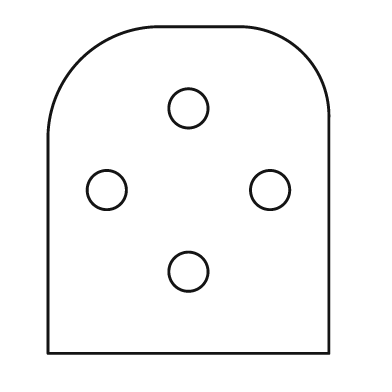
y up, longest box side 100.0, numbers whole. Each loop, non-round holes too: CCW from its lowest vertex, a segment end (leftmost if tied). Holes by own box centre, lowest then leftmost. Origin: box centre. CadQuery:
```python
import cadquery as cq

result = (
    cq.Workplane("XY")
    .moveTo(-43.0, -50.0)
    .lineTo(43.0, -50.0)
    .lineTo(43.0, 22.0)
    .threePointArc((35.0, 42.0), (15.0, 50.0))
    .lineTo(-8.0, 50.0)
    .threePointArc((-33.0, 40.0), (-43.0, 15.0))
    .close()
    .moveTo(0.0, -25.0)
    .circle(6.0)
    .moveTo(-25.0, 0.0)
    .circle(6.0)
    .moveTo(25.0, 0.0)
    .circle(6.0)
    .moveTo(0.0, 25.0)
    .circle(6.0)
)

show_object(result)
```